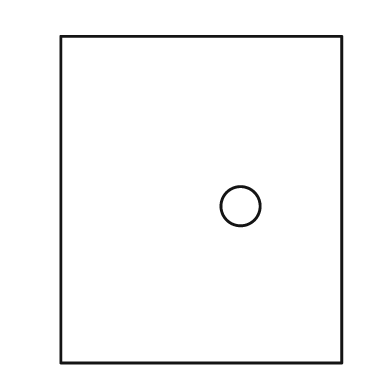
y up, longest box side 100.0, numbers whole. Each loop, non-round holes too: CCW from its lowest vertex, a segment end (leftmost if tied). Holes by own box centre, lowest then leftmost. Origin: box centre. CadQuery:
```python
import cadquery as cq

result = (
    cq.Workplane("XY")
    .moveTo(-43.0, -50.0)
    .lineTo(43.0, -50.0)
    .lineTo(43.0, 50.0)
    .lineTo(-43.0, 50.0)
    .close()
    .moveTo(12.0, -2.0)
    .circle(6.0)
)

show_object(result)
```